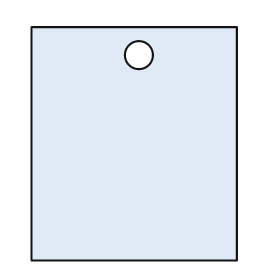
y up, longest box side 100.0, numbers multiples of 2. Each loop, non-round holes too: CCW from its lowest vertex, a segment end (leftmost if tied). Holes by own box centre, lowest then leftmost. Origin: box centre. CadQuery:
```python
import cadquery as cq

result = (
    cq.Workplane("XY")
    .moveTo(-44.0, -50.0)
    .lineTo(44.0, -50.0)
    .lineTo(44.0, 50.0)
    .lineTo(-44.0, 50.0)
    .close()
    .moveTo(2.0, 38.0)
    .circle(6.0)
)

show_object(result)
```